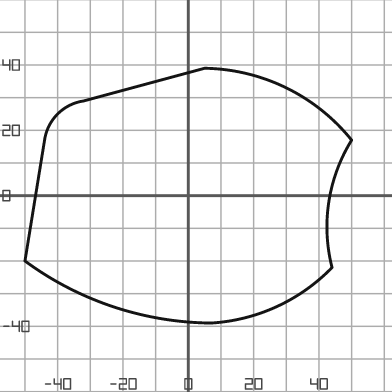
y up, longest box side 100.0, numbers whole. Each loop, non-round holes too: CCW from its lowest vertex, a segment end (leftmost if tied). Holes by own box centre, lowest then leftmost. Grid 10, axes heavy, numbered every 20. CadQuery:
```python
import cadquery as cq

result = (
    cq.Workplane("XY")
    .moveTo(7.0, -39.0)
    .threePointArc((27.0, -34.0), (44.0, -22.0))
    .threePointArc((43.0, -2.0), (50.0, 17.0))
    .threePointArc((30.0, 33.0), (5.0, 39.0))
    .lineTo(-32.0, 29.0)
    .threePointArc((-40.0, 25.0), (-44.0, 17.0))
    .lineTo(-50.0, -20.0)
    .threePointArc((-23.0, -34.0), (7.0, -39.0))
    .close()
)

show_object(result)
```